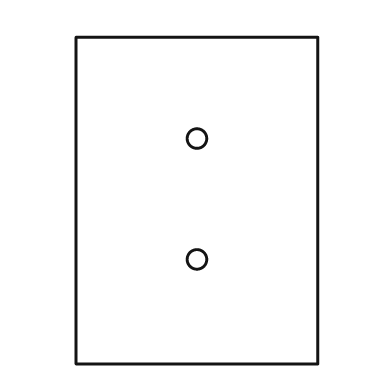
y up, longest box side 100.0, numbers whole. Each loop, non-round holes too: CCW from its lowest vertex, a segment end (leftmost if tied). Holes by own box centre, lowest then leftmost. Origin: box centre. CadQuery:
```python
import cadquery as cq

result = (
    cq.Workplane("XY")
    .moveTo(-37.0, -50.0)
    .lineTo(37.0, -50.0)
    .lineTo(37.0, 50.0)
    .lineTo(-37.0, 50.0)
    .close()
    .moveTo(0.0, -18.0)
    .circle(3.0)
    .moveTo(0.0, 19.0)
    .circle(3.0)
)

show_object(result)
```